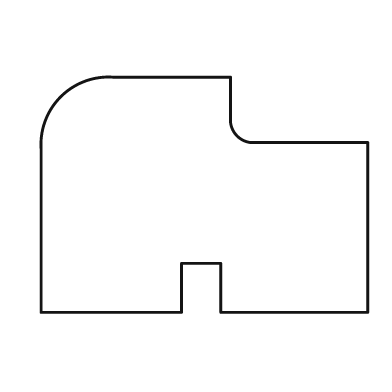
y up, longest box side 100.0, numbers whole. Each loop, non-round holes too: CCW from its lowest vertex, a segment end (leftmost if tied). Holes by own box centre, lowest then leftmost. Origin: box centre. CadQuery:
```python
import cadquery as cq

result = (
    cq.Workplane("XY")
    .moveTo(-50.0, -36.0)
    .lineTo(-7.0, -36.0)
    .lineTo(-7.0, -21.0)
    .lineTo(5.0, -21.0)
    .lineTo(5.0, -36.0)
    .lineTo(50.0, -36.0)
    .lineTo(50.0, 16.0)
    .lineTo(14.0, 16.0)
    .threePointArc((10.0, 18.0), (8.0, 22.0))
    .lineTo(8.0, 36.0)
    .lineTo(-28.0, 36.0)
    .threePointArc((-44.0, 30.0), (-50.0, 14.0))
    .close()
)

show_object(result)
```